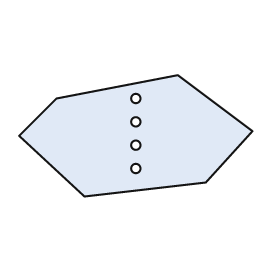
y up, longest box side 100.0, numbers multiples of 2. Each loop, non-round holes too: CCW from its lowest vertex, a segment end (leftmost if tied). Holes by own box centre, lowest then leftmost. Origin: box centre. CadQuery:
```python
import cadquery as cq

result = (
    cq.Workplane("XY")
    .moveTo(-22.0, -26.0)
    .lineTo(30.0, -20.0)
    .lineTo(50.0, 2.0)
    .lineTo(18.0, 26.0)
    .lineTo(-34.0, 16.0)
    .lineTo(-50.0, 0.0)
    .close()
    .moveTo(0.0, -14.0)
    .circle(2.0)
    .moveTo(0.0, -4.0)
    .circle(2.0)
    .moveTo(0.0, 6.0)
    .circle(2.0)
    .moveTo(0.0, 16.0)
    .circle(2.0)
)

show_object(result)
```